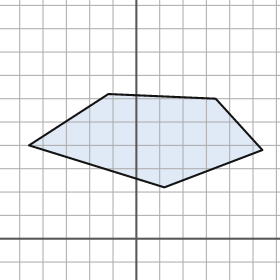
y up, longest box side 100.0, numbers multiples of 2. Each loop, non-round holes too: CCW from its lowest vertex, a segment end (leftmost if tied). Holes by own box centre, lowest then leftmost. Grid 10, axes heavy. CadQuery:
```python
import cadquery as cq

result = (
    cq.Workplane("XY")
    .moveTo(12.0, 22.0)
    .lineTo(54.0, 38.0)
    .lineTo(34.0, 60.0)
    .lineTo(-12.0, 62.0)
    .lineTo(-46.0, 40.0)
    .close()
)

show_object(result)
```